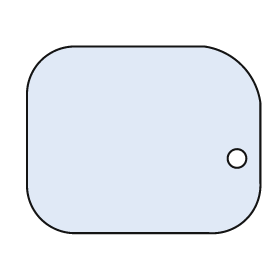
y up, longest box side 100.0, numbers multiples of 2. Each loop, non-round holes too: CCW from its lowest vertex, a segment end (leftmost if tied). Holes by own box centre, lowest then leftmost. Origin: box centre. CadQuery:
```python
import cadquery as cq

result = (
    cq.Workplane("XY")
    .moveTo(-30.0, -40.0)
    .lineTo(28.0, -40.0)
    .threePointArc((44.0, -34.0), (50.0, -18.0))
    .lineTo(50.0, 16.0)
    .threePointArc((42.0, 32.0), (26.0, 40.0))
    .lineTo(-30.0, 40.0)
    .threePointArc((-44.0, 34.0), (-50.0, 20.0))
    .lineTo(-50.0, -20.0)
    .threePointArc((-44.0, -34.0), (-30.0, -40.0))
    .close()
    .moveTo(40.0, -8.0)
    .circle(4.0)
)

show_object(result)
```